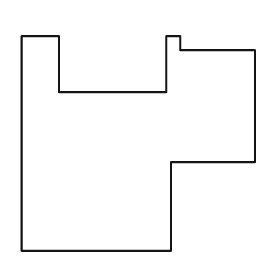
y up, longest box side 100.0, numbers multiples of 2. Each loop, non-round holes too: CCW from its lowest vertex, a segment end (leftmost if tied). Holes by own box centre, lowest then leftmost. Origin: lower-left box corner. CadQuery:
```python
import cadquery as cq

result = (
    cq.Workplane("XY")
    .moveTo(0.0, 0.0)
    .lineTo(64.0, 0.0)
    .lineTo(64.0, 38.0)
    .lineTo(100.0, 38.0)
    .lineTo(100.0, 86.0)
    .lineTo(68.0, 86.0)
    .lineTo(68.0, 92.0)
    .lineTo(62.0, 92.0)
    .lineTo(62.0, 68.0)
    .lineTo(16.0, 68.0)
    .lineTo(16.0, 92.0)
    .lineTo(0.0, 92.0)
    .close()
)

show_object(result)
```